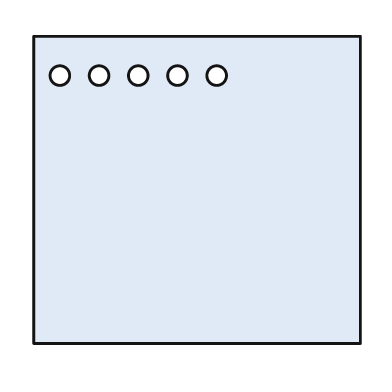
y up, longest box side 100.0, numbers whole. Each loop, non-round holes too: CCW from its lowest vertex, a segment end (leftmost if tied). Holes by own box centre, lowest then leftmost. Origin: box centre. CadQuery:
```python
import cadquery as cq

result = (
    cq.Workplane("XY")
    .moveTo(-50.0, -47.0)
    .lineTo(50.0, -47.0)
    .lineTo(50.0, 47.0)
    .lineTo(-50.0, 47.0)
    .close()
    .moveTo(-42.0, 35.0)
    .circle(3.0)
    .moveTo(-30.0, 35.0)
    .circle(3.0)
    .moveTo(-18.0, 35.0)
    .circle(3.0)
    .moveTo(-6.0, 35.0)
    .circle(3.0)
    .moveTo(6.0, 35.0)
    .circle(3.0)
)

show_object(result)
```